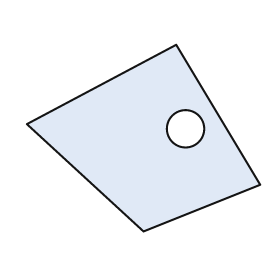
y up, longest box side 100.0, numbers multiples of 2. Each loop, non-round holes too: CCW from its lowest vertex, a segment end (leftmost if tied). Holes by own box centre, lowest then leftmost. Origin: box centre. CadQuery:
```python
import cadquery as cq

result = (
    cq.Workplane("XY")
    .moveTo(0.0, -40.0)
    .lineTo(50.0, -20.0)
    .lineTo(14.0, 40.0)
    .lineTo(-50.0, 6.0)
    .close()
    .moveTo(18.0, 4.0)
    .circle(8.0)
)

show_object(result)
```